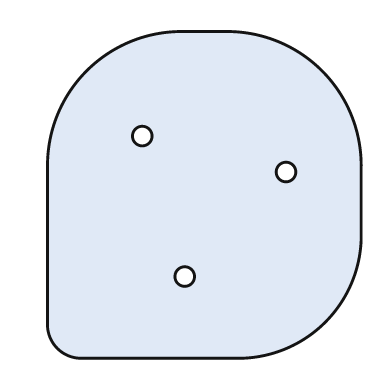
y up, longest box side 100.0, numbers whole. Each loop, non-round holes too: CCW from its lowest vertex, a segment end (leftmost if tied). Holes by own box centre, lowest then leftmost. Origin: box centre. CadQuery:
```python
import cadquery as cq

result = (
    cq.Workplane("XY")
    .moveTo(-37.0, -50.0)
    .lineTo(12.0, -50.0)
    .threePointArc((37.0, -39.0), (48.0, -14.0))
    .lineTo(48.0, 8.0)
    .threePointArc((36.0, 38.0), (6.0, 50.0))
    .lineTo(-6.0, 50.0)
    .threePointArc((-36.0, 38.0), (-48.0, 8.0))
    .lineTo(-48.0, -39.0)
    .threePointArc((-45.0, -47.0), (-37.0, -50.0))
    .close()
    .moveTo(-6.0, -25.0)
    .circle(3.0)
    .moveTo(25.0, 7.0)
    .circle(3.0)
    .moveTo(-19.0, 18.0)
    .circle(3.0)
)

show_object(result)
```